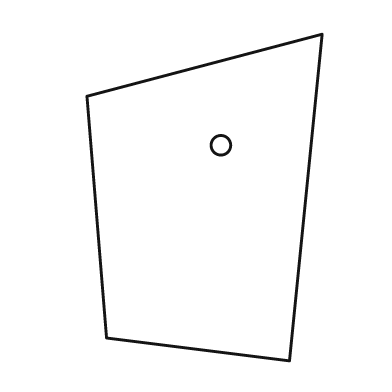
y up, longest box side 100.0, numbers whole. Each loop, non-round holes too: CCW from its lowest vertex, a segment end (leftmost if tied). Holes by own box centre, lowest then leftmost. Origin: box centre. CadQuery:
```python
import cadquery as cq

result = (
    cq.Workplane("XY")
    .moveTo(26.0, -50.0)
    .lineTo(36.0, 50.0)
    .lineTo(-36.0, 31.0)
    .lineTo(-30.0, -43.0)
    .close()
    .moveTo(5.0, 16.0)
    .circle(3.0)
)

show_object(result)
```